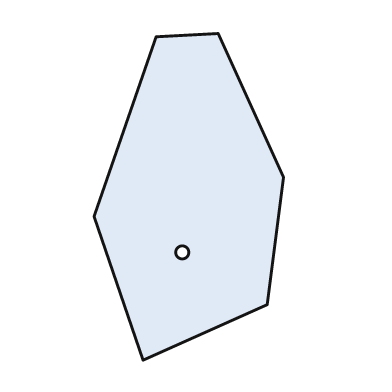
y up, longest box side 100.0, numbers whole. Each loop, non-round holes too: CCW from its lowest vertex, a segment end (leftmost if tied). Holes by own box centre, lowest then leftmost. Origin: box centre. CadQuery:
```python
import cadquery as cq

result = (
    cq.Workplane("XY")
    .moveTo(-14.0, -50.0)
    .lineTo(24.0, -33.0)
    .lineTo(29.0, 6.0)
    .lineTo(9.0, 50.0)
    .lineTo(-10.0, 49.0)
    .lineTo(-29.0, -6.0)
    .close()
    .moveTo(-2.0, -17.0)
    .circle(2.0)
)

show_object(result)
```